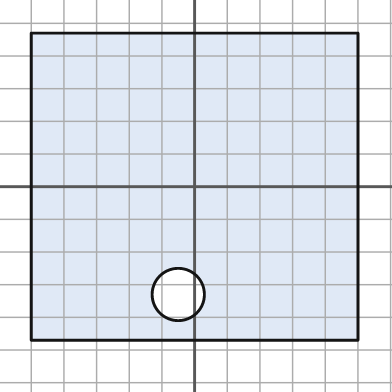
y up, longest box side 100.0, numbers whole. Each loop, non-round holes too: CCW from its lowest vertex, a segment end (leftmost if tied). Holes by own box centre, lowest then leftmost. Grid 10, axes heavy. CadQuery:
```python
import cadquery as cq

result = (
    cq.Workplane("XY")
    .moveTo(-50.0, -47.0)
    .lineTo(50.0, -47.0)
    .lineTo(50.0, 47.0)
    .lineTo(-50.0, 47.0)
    .close()
    .moveTo(-5.0, -33.0)
    .circle(8.0)
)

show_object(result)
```